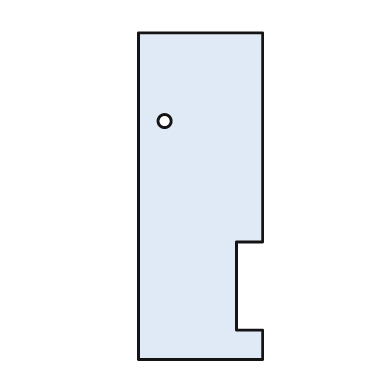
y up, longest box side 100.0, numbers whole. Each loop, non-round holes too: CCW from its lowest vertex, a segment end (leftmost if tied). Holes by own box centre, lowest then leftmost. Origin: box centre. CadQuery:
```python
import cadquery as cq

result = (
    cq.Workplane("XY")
    .moveTo(-19.0, -50.0)
    .lineTo(19.0, -50.0)
    .lineTo(19.0, -41.0)
    .lineTo(11.0, -41.0)
    .lineTo(11.0, -14.0)
    .lineTo(19.0, -14.0)
    .lineTo(19.0, 50.0)
    .lineTo(-19.0, 50.0)
    .close()
    .moveTo(-11.0, 23.0)
    .circle(2.0)
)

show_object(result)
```